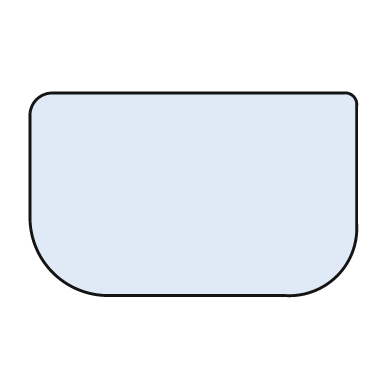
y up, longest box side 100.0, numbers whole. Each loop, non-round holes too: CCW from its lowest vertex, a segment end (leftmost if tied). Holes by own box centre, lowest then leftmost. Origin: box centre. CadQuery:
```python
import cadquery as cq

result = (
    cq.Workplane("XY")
    .moveTo(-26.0, -31.0)
    .lineTo(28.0, -31.0)
    .threePointArc((44.0, -25.0), (50.0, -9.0))
    .lineTo(50.0, 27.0)
    .threePointArc((49.0, 30.0), (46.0, 31.0))
    .lineTo(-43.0, 31.0)
    .threePointArc((-48.0, 29.0), (-50.0, 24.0))
    .lineTo(-50.0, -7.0)
    .threePointArc((-43.0, -24.0), (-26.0, -31.0))
    .close()
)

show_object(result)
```